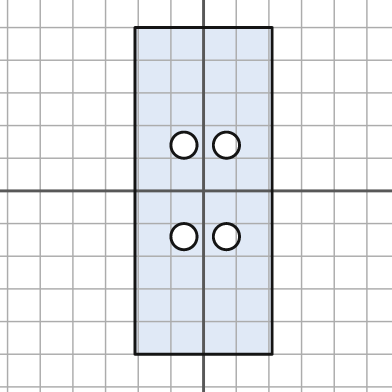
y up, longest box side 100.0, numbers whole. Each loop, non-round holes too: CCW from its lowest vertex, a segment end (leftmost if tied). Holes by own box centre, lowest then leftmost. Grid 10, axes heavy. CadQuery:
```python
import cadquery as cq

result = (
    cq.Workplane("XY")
    .moveTo(-21.0, -50.0)
    .lineTo(21.0, -50.0)
    .lineTo(21.0, 50.0)
    .lineTo(-21.0, 50.0)
    .close()
    .moveTo(-6.0, -14.0)
    .circle(4.0)
    .moveTo(7.0, -14.0)
    .circle(4.0)
    .moveTo(-6.0, 14.0)
    .circle(4.0)
    .moveTo(7.0, 14.0)
    .circle(4.0)
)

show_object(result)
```